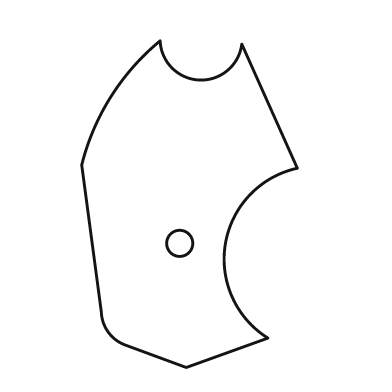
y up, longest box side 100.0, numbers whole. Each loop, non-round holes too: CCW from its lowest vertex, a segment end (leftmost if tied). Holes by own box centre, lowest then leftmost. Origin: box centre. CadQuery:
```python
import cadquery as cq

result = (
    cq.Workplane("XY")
    .moveTo(-1.0, -50.0)
    .lineTo(24.0, -41.0)
    .threePointArc((11.0, -12.0), (33.0, 11.0))
    .lineTo(16.0, 49.0)
    .threePointArc((3.0, 38.0), (-9.0, 50.0))
    .threePointArc((-24.0, 33.0), (-33.0, 12.0))
    .lineTo(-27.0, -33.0)
    .threePointArc((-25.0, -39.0), (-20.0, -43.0))
    .close()
    .moveTo(-3.0, -12.0)
    .circle(4.0)
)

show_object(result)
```